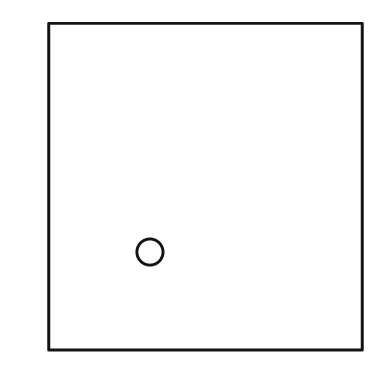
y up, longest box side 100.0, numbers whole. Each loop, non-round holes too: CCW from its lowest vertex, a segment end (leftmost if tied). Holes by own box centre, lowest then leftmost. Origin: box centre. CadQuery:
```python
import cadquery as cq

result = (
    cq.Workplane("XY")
    .moveTo(-48.0, -50.0)
    .lineTo(48.0, -50.0)
    .lineTo(48.0, 50.0)
    .lineTo(-48.0, 50.0)
    .close()
    .moveTo(-17.0, -20.0)
    .circle(4.0)
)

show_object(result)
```